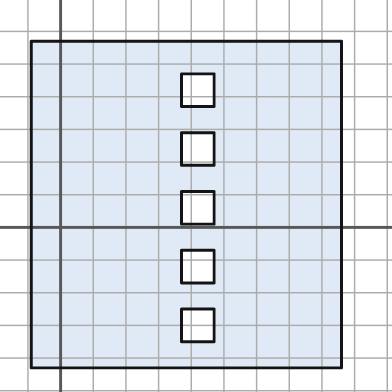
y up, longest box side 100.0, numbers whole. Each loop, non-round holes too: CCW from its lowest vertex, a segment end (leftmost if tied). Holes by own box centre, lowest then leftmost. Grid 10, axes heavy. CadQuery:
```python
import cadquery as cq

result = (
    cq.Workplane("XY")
    .moveTo(-9.0, -43.0)
    .lineTo(86.0, -43.0)
    .lineTo(86.0, 57.0)
    .lineTo(-9.0, 57.0)
    .close()
    .moveTo(37.0, -35.0)
    .lineTo(47.0, -35.0)
    .lineTo(47.0, -25.0)
    .lineTo(37.0, -25.0)
    .close()
    .moveTo(37.0, -17.0)
    .lineTo(47.0, -17.0)
    .lineTo(47.0, -7.0)
    .lineTo(37.0, -7.0)
    .close()
    .moveTo(37.0, 1.0)
    .lineTo(47.0, 1.0)
    .lineTo(47.0, 11.0)
    .lineTo(37.0, 11.0)
    .close()
    .moveTo(37.0, 19.0)
    .lineTo(47.0, 19.0)
    .lineTo(47.0, 29.0)
    .lineTo(37.0, 29.0)
    .close()
    .moveTo(37.0, 37.0)
    .lineTo(47.0, 37.0)
    .lineTo(47.0, 47.0)
    .lineTo(37.0, 47.0)
    .close()
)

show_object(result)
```